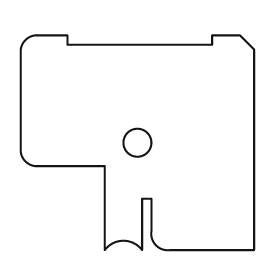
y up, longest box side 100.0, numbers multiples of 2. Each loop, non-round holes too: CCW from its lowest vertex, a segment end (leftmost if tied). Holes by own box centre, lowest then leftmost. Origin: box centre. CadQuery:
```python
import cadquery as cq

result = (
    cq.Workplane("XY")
    .moveTo(-14.0, -46.0)
    .threePointArc((-6.0, -42.0), (2.0, -46.0))
    .lineTo(2.0, -24.0)
    .lineTo(6.0, -24.0)
    .lineTo(6.0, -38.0)
    .threePointArc((8.0, -44.0), (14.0, -46.0))
    .lineTo(50.0, -46.0)
    .lineTo(50.0, 40.0)
    .lineTo(44.0, 46.0)
    .lineTo(32.0, 46.0)
    .lineTo(32.0, 42.0)
    .lineTo(-30.0, 42.0)
    .lineTo(-30.0, 46.0)
    .lineTo(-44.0, 46.0)
    .threePointArc((-48.0, 44.0), (-50.0, 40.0))
    .lineTo(-50.0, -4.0)
    .threePointArc((-48.0, -8.0), (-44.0, -10.0))
    .lineTo(-14.0, -10.0)
    .close()
    .moveTo(0.0, 0.0)
    .circle(6.0)
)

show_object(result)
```